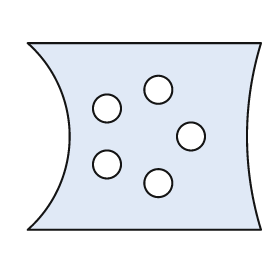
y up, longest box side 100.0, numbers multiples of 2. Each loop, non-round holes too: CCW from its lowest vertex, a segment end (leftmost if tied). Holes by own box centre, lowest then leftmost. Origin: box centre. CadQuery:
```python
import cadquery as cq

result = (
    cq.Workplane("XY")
    .moveTo(-50.0, -40.0)
    .lineTo(50.0, -40.0)
    .threePointArc((44.0, 0.0), (50.0, 40.0))
    .lineTo(-50.0, 40.0)
    .threePointArc((-32.0, 0.0), (-50.0, -40.0))
    .close()
    .moveTo(6.0, -20.0)
    .circle(6.0)
    .moveTo(-16.0, -12.0)
    .circle(6.0)
    .moveTo(20.0, 0.0)
    .circle(6.0)
    .moveTo(-16.0, 12.0)
    .circle(6.0)
    .moveTo(6.0, 20.0)
    .circle(6.0)
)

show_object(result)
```